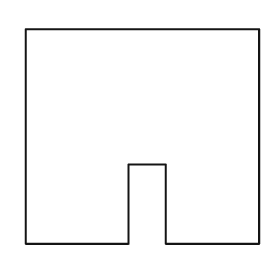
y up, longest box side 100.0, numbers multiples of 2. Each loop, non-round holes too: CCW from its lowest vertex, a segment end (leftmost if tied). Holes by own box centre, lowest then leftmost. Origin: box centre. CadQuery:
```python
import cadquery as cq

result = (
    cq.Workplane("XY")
    .moveTo(-50.0, -46.0)
    .lineTo(-6.0, -46.0)
    .lineTo(-6.0, -12.0)
    .lineTo(10.0, -12.0)
    .lineTo(10.0, -46.0)
    .lineTo(50.0, -46.0)
    .lineTo(50.0, 46.0)
    .lineTo(-50.0, 46.0)
    .close()
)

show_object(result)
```